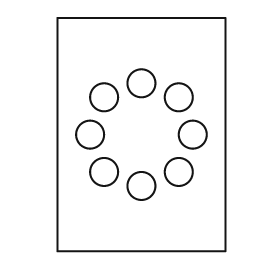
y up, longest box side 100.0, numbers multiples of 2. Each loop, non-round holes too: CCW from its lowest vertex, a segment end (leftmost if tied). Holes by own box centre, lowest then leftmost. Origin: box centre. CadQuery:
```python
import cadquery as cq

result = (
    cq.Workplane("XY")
    .moveTo(-36.0, -50.0)
    .lineTo(36.0, -50.0)
    .lineTo(36.0, 50.0)
    .lineTo(-36.0, 50.0)
    .close()
    .moveTo(0.0, -22.0)
    .circle(6.0)
    .moveTo(-16.0, -16.0)
    .circle(6.0)
    .moveTo(16.0, -16.0)
    .circle(6.0)
    .moveTo(-22.0, 0.0)
    .circle(6.0)
    .moveTo(22.0, 0.0)
    .circle(6.0)
    .moveTo(-16.0, 16.0)
    .circle(6.0)
    .moveTo(16.0, 16.0)
    .circle(6.0)
    .moveTo(0.0, 22.0)
    .circle(6.0)
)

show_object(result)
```